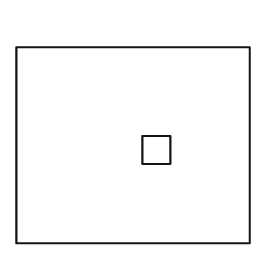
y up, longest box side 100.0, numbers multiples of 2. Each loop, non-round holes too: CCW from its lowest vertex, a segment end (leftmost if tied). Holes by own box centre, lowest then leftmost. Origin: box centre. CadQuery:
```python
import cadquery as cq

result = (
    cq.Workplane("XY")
    .moveTo(-50.0, -42.0)
    .lineTo(50.0, -42.0)
    .lineTo(50.0, 42.0)
    .lineTo(-50.0, 42.0)
    .close()
    .moveTo(4.0, -8.0)
    .lineTo(16.0, -8.0)
    .lineTo(16.0, 4.0)
    .lineTo(4.0, 4.0)
    .close()
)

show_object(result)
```